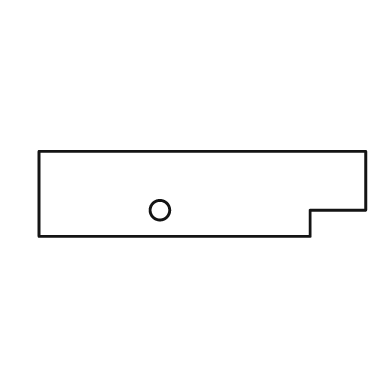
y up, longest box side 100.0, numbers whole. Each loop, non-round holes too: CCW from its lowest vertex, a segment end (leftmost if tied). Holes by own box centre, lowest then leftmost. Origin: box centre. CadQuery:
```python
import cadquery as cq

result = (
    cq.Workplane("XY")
    .moveTo(-50.0, -13.0)
    .lineTo(33.0, -13.0)
    .lineTo(33.0, -5.0)
    .lineTo(50.0, -5.0)
    .lineTo(50.0, 13.0)
    .lineTo(-50.0, 13.0)
    .close()
    .moveTo(-13.0, -5.0)
    .circle(3.0)
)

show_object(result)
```